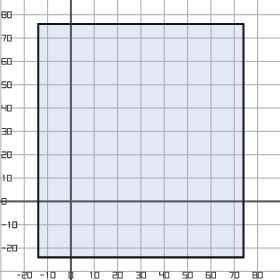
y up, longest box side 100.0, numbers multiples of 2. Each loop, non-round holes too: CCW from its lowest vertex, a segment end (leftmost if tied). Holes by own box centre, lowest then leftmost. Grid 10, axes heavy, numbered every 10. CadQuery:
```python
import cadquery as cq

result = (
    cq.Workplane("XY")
    .moveTo(-14.0, -24.0)
    .lineTo(74.0, -24.0)
    .lineTo(74.0, 76.0)
    .lineTo(-14.0, 76.0)
    .close()
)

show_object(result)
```